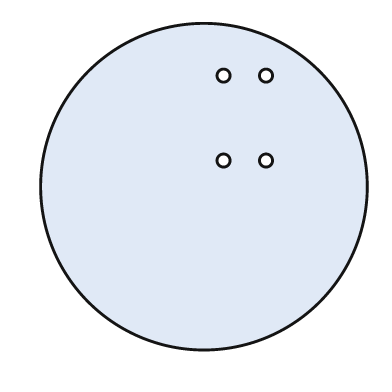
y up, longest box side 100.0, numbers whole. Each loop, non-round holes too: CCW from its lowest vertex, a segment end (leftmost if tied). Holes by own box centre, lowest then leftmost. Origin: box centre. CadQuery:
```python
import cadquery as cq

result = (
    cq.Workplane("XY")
    .moveTo(0.0, 0.0)
    .circle(50.0)
    .moveTo(6.0, 8.0)
    .circle(2.0)
    .moveTo(19.0, 8.0)
    .circle(2.0)
    .moveTo(6.0, 34.0)
    .circle(2.0)
    .moveTo(19.0, 34.0)
    .circle(2.0)
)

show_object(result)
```